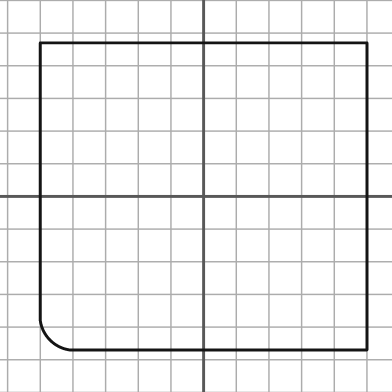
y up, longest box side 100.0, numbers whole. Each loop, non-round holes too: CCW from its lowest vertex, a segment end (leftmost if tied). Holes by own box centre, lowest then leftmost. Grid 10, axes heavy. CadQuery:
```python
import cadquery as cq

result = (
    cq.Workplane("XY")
    .moveTo(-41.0, -47.0)
    .lineTo(50.0, -47.0)
    .lineTo(50.0, 47.0)
    .lineTo(-50.0, 47.0)
    .lineTo(-50.0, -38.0)
    .threePointArc((-47.0, -44.0), (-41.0, -47.0))
    .close()
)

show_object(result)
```